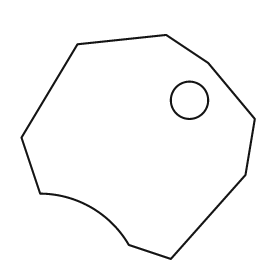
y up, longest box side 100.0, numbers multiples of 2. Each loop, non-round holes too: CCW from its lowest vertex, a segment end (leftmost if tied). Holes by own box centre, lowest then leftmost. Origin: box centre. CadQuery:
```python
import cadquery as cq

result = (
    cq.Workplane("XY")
    .moveTo(14.0, -48.0)
    .lineTo(46.0, -12.0)
    .lineTo(50.0, 12.0)
    .lineTo(30.0, 36.0)
    .lineTo(12.0, 48.0)
    .lineTo(-26.0, 44.0)
    .lineTo(-50.0, 4.0)
    .lineTo(-42.0, -20.0)
    .threePointArc((-20.0, -26.0), (-4.0, -42.0))
    .close()
    .moveTo(22.0, 20.0)
    .circle(8.0)
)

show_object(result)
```